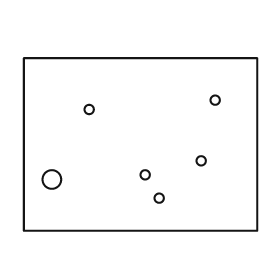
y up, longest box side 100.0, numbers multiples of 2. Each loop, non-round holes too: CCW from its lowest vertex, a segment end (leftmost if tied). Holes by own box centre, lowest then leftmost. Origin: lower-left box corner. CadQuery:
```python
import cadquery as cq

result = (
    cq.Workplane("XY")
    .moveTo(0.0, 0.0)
    .lineTo(100.0, 0.0)
    .lineTo(100.0, 74.0)
    .lineTo(0.0, 74.0)
    .close()
    .moveTo(58.0, 14.0)
    .circle(2.0)
    .moveTo(12.0, 22.0)
    .circle(4.0)
    .moveTo(52.0, 24.0)
    .circle(2.0)
    .moveTo(76.0, 30.0)
    .circle(2.0)
    .moveTo(28.0, 52.0)
    .circle(2.0)
    .moveTo(82.0, 56.0)
    .circle(2.0)
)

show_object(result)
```